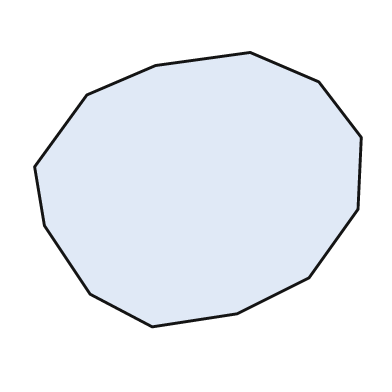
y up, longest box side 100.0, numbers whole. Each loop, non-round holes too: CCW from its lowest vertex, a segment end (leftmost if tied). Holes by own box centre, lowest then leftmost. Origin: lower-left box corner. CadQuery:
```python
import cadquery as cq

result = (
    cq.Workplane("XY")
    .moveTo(36.0, 0.0)
    .lineTo(62.0, 4.0)
    .lineTo(84.0, 15.0)
    .lineTo(99.0, 36.0)
    .lineTo(100.0, 58.0)
    .lineTo(87.0, 75.0)
    .lineTo(66.0, 84.0)
    .lineTo(37.0, 80.0)
    .lineTo(16.0, 71.0)
    .lineTo(0.0, 49.0)
    .lineTo(3.0, 31.0)
    .lineTo(17.0, 10.0)
    .close()
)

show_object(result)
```